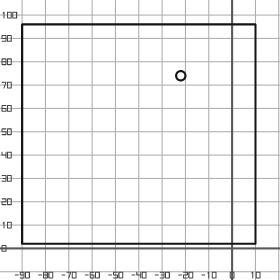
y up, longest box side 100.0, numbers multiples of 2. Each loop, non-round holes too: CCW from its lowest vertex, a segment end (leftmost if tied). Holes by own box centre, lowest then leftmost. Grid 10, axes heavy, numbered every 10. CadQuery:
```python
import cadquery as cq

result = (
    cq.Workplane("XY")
    .moveTo(-90.0, 2.0)
    .lineTo(10.0, 2.0)
    .lineTo(10.0, 96.0)
    .lineTo(-90.0, 96.0)
    .close()
    .moveTo(-22.0, 74.0)
    .circle(2.0)
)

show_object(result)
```